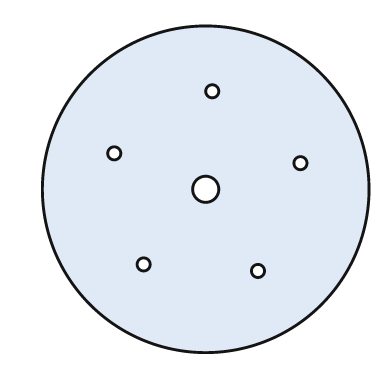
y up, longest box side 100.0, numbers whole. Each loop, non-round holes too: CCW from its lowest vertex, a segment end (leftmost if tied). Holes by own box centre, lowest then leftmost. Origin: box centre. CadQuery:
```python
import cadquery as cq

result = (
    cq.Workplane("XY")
    .moveTo(0.0, 0.0)
    .circle(50.0)
    .moveTo(16.0, -25.0)
    .circle(2.0)
    .moveTo(-19.0, -23.0)
    .circle(2.0)
    .moveTo(0.0, 0.0)
    .circle(4.0)
    .moveTo(29.0, 8.0)
    .circle(2.0)
    .moveTo(-28.0, 11.0)
    .circle(2.0)
    .moveTo(2.0, 30.0)
    .circle(2.0)
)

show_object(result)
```